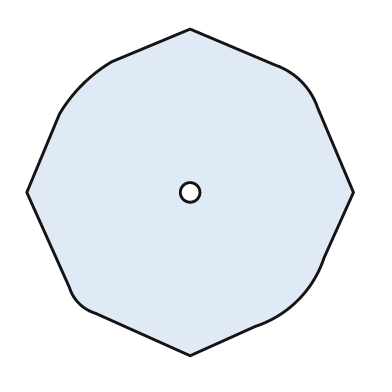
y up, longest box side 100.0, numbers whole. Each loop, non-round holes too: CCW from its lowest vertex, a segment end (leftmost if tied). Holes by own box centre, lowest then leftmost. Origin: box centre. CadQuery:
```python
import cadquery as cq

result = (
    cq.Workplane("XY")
    .moveTo(0.0, -50.0)
    .lineTo(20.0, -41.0)
    .threePointArc((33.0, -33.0), (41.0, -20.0))
    .lineTo(50.0, 0.0)
    .lineTo(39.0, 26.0)
    .threePointArc((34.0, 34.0), (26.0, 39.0))
    .lineTo(0.0, 50.0)
    .lineTo(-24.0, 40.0)
    .threePointArc((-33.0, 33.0), (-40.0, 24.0))
    .lineTo(-50.0, 0.0)
    .lineTo(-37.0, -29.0)
    .threePointArc((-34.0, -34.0), (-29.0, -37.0))
    .close()
    .moveTo(0.0, 0.0)
    .circle(3.0)
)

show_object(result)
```